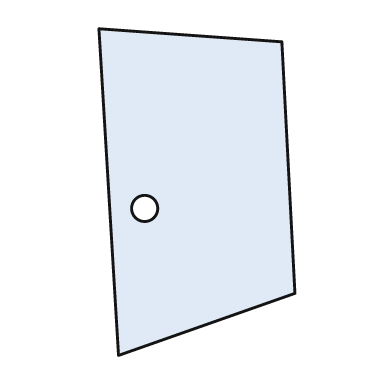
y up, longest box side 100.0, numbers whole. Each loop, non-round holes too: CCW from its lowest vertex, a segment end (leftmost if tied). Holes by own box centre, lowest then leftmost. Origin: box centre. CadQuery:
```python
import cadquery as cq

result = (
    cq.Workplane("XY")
    .moveTo(-24.0, -50.0)
    .lineTo(30.0, -31.0)
    .lineTo(26.0, 46.0)
    .lineTo(-30.0, 50.0)
    .close()
    .moveTo(-16.0, -5.0)
    .circle(4.0)
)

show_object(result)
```